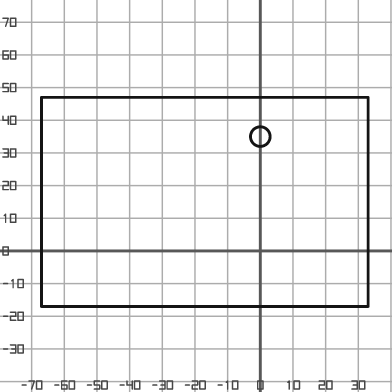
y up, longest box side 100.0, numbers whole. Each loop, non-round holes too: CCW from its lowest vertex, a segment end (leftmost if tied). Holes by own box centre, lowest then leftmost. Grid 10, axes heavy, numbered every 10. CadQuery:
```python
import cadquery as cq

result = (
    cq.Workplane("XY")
    .moveTo(-67.0, -17.0)
    .lineTo(33.0, -17.0)
    .lineTo(33.0, 47.0)
    .lineTo(-67.0, 47.0)
    .close()
    .moveTo(0.0, 35.0)
    .circle(3.0)
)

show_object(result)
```